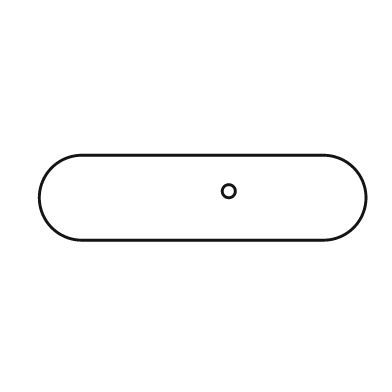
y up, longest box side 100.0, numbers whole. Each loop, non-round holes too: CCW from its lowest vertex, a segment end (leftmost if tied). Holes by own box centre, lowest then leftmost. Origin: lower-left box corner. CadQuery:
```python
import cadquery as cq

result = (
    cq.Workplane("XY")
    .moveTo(13.0, 0.0)
    .lineTo(87.0, 0.0)
    .threePointArc((100.0, 13.0), (87.0, 26.0))
    .lineTo(13.0, 26.0)
    .threePointArc((0.0, 13.0), (13.0, 0.0))
    .close()
    .moveTo(58.0, 15.0)
    .circle(2.0)
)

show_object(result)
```